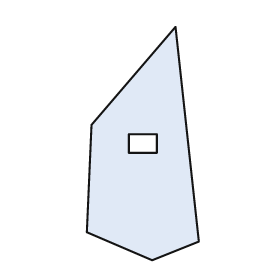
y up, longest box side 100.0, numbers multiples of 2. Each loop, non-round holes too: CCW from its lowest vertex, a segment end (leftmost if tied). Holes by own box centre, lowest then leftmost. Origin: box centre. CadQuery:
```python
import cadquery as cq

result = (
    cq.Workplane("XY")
    .moveTo(4.0, -50.0)
    .lineTo(24.0, -42.0)
    .lineTo(14.0, 50.0)
    .lineTo(-22.0, 8.0)
    .lineTo(-24.0, -38.0)
    .close()
    .moveTo(-6.0, -4.0)
    .lineTo(6.0, -4.0)
    .lineTo(6.0, 4.0)
    .lineTo(-6.0, 4.0)
    .close()
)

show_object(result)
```